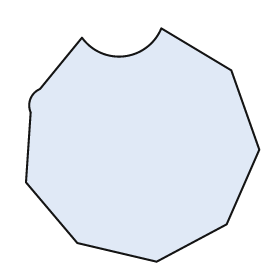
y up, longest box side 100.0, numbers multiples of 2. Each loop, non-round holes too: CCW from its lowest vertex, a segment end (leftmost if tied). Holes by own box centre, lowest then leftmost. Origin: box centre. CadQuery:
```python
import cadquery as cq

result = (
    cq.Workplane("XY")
    .moveTo(6.0, -50.0)
    .lineTo(36.0, -34.0)
    .lineTo(50.0, -2.0)
    .lineTo(38.0, 32.0)
    .lineTo(8.0, 50.0)
    .threePointArc((-8.0, 38.0), (-26.0, 46.0))
    .lineTo(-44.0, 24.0)
    .threePointArc((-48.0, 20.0), (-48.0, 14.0))
    .lineTo(-50.0, -16.0)
    .lineTo(-28.0, -42.0)
    .close()
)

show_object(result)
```